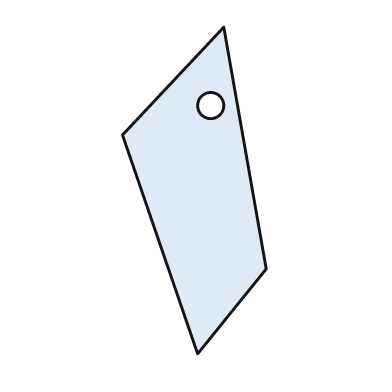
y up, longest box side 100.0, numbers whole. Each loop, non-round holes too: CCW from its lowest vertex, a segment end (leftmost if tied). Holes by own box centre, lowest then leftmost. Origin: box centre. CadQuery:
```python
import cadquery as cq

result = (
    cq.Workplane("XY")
    .moveTo(1.0, -50.0)
    .lineTo(22.0, -24.0)
    .lineTo(9.0, 50.0)
    .lineTo(-22.0, 17.0)
    .close()
    .moveTo(5.0, 26.0)
    .circle(4.0)
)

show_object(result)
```